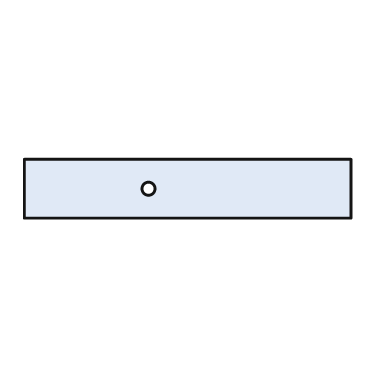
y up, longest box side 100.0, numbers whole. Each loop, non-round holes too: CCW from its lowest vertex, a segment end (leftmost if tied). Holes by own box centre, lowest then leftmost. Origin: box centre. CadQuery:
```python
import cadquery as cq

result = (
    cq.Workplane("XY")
    .moveTo(-50.0, -9.0)
    .lineTo(50.0, -9.0)
    .lineTo(50.0, 9.0)
    .lineTo(-50.0, 9.0)
    .close()
    .moveTo(-12.0, 0.0)
    .circle(2.0)
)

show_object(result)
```